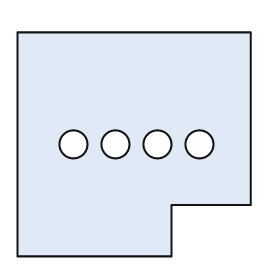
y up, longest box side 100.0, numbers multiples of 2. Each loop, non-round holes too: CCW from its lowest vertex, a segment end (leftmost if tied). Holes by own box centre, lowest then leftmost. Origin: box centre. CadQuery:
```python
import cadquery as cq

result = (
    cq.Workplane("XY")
    .moveTo(-50.0, -48.0)
    .lineTo(16.0, -48.0)
    .lineTo(16.0, -26.0)
    .lineTo(50.0, -26.0)
    .lineTo(50.0, 48.0)
    .lineTo(-50.0, 48.0)
    .close()
    .moveTo(-26.0, 0.0)
    .circle(6.0)
    .moveTo(-8.0, 0.0)
    .circle(6.0)
    .moveTo(10.0, 0.0)
    .circle(6.0)
    .moveTo(28.0, 0.0)
    .circle(6.0)
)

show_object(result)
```